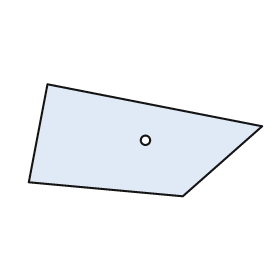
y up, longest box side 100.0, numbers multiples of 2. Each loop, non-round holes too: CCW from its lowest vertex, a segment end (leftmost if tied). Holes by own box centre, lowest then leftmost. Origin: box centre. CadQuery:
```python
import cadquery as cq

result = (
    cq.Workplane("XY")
    .moveTo(16.0, -24.0)
    .lineTo(50.0, 6.0)
    .lineTo(-42.0, 24.0)
    .lineTo(-50.0, -18.0)
    .close()
    .moveTo(0.0, 0.0)
    .circle(2.0)
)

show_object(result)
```